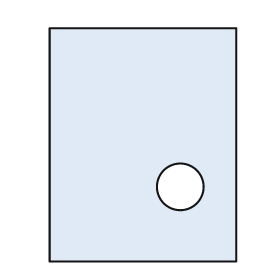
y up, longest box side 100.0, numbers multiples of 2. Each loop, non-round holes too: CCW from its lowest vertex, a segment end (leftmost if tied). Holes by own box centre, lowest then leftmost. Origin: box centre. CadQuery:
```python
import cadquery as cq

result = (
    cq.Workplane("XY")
    .moveTo(-40.0, -50.0)
    .lineTo(40.0, -50.0)
    .lineTo(40.0, 50.0)
    .lineTo(-40.0, 50.0)
    .close()
    .moveTo(16.0, -18.0)
    .circle(10.0)
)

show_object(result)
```